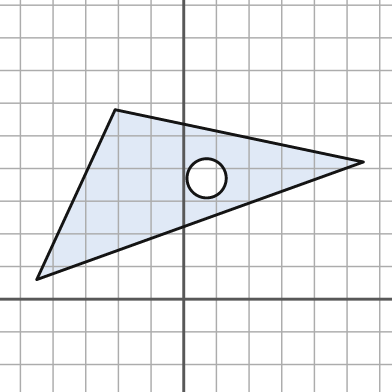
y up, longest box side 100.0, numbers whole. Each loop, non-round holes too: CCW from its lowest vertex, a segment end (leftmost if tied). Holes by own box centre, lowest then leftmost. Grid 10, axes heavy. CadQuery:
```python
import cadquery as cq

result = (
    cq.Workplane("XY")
    .moveTo(-45.0, 6.0)
    .lineTo(55.0, 42.0)
    .lineTo(-21.0, 58.0)
    .close()
    .moveTo(7.0, 37.0)
    .circle(6.0)
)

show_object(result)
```